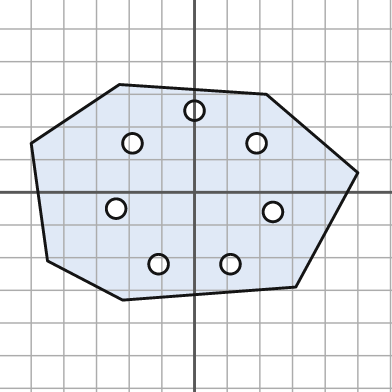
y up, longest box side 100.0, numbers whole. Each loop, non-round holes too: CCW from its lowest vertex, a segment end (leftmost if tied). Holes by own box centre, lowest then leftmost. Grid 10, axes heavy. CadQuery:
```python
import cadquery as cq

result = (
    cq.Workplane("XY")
    .moveTo(-22.0, -33.0)
    .lineTo(31.0, -29.0)
    .lineTo(50.0, 6.0)
    .lineTo(22.0, 30.0)
    .lineTo(-23.0, 33.0)
    .lineTo(-50.0, 15.0)
    .lineTo(-45.0, -21.0)
    .close()
    .moveTo(-11.0, -22.0)
    .circle(3.0)
    .moveTo(11.0, -22.0)
    .circle(3.0)
    .moveTo(24.0, -6.0)
    .circle(3.0)
    .moveTo(-24.0, -5.0)
    .circle(3.0)
    .moveTo(-19.0, 15.0)
    .circle(3.0)
    .moveTo(19.0, 15.0)
    .circle(3.0)
    .moveTo(0.0, 25.0)
    .circle(3.0)
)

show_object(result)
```